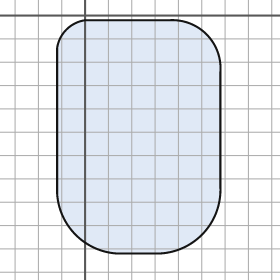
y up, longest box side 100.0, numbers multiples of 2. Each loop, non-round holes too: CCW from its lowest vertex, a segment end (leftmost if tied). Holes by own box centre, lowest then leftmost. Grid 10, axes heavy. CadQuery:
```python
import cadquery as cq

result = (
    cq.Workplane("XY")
    .moveTo(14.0, -102.0)
    .lineTo(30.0, -102.0)
    .threePointArc((50.0, -94.0), (58.0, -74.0))
    .lineTo(58.0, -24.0)
    .threePointArc((52.0, -8.0), (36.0, -2.0))
    .lineTo(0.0, -2.0)
    .threePointArc((-8.0, -6.0), (-12.0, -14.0))
    .lineTo(-12.0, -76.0)
    .threePointArc((-4.0, -94.0), (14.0, -102.0))
    .close()
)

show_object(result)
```